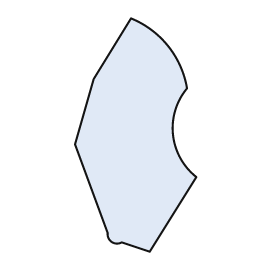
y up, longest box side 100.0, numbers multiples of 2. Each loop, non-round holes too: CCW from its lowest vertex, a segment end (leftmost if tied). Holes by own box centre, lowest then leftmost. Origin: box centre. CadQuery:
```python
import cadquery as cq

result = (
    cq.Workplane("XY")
    .moveTo(6.0, -50.0)
    .lineTo(26.0, -18.0)
    .threePointArc((16.0, 0.0), (22.0, 20.0))
    .threePointArc((14.0, 38.0), (-2.0, 50.0))
    .lineTo(-18.0, 24.0)
    .lineTo(-26.0, -4.0)
    .lineTo(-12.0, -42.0)
    .threePointArc((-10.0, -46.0), (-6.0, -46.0))
    .close()
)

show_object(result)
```